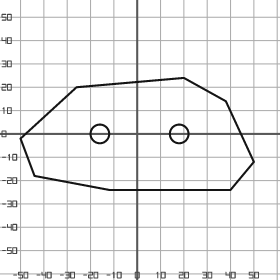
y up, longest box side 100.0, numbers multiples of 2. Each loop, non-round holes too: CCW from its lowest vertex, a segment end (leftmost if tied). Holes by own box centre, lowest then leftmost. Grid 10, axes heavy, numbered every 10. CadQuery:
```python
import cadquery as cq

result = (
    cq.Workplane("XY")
    .moveTo(-12.0, -24.0)
    .lineTo(40.0, -24.0)
    .lineTo(50.0, -12.0)
    .lineTo(38.0, 14.0)
    .lineTo(20.0, 24.0)
    .lineTo(-26.0, 20.0)
    .lineTo(-50.0, -2.0)
    .lineTo(-44.0, -18.0)
    .close()
    .moveTo(-16.0, 0.0)
    .circle(4.0)
    .moveTo(18.0, 0.0)
    .circle(4.0)
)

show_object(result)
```